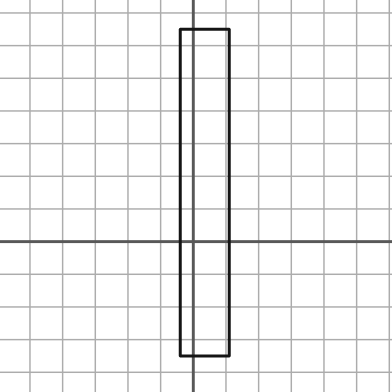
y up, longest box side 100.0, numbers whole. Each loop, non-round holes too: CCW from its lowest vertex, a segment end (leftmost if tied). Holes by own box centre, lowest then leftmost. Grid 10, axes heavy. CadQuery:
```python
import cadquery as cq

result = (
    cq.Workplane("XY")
    .moveTo(-4.0, -35.0)
    .lineTo(11.0, -35.0)
    .lineTo(11.0, 65.0)
    .lineTo(-4.0, 65.0)
    .close()
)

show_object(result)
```